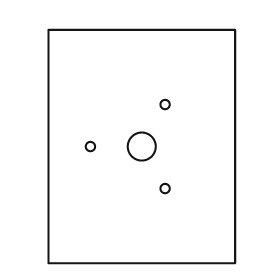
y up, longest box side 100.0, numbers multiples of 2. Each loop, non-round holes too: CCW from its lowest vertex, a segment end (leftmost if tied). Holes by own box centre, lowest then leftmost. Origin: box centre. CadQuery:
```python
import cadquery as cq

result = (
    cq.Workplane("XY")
    .moveTo(-40.0, -50.0)
    .lineTo(40.0, -50.0)
    .lineTo(40.0, 50.0)
    .lineTo(-40.0, 50.0)
    .close()
    .moveTo(10.0, -18.0)
    .circle(2.0)
    .moveTo(-22.0, 0.0)
    .circle(2.0)
    .moveTo(0.0, 0.0)
    .circle(6.0)
    .moveTo(10.0, 18.0)
    .circle(2.0)
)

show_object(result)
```